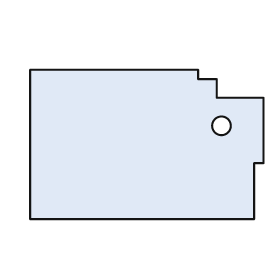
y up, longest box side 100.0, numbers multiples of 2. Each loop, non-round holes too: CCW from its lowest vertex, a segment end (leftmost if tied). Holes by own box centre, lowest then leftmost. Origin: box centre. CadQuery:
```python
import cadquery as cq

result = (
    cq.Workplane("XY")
    .moveTo(-50.0, -32.0)
    .lineTo(46.0, -32.0)
    .lineTo(46.0, -8.0)
    .lineTo(50.0, -8.0)
    .lineTo(50.0, 20.0)
    .lineTo(30.0, 20.0)
    .lineTo(30.0, 28.0)
    .lineTo(22.0, 28.0)
    .lineTo(22.0, 32.0)
    .lineTo(-50.0, 32.0)
    .close()
    .moveTo(32.0, 8.0)
    .circle(4.0)
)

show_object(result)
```